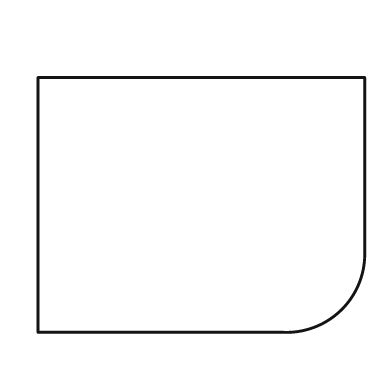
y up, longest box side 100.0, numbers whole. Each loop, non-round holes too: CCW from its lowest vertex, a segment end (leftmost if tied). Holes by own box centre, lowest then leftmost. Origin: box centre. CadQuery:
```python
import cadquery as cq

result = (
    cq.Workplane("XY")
    .moveTo(-50.0, -39.0)
    .lineTo(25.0, -39.0)
    .threePointArc((43.0, -32.0), (50.0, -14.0))
    .lineTo(50.0, 39.0)
    .lineTo(-50.0, 39.0)
    .close()
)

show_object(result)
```